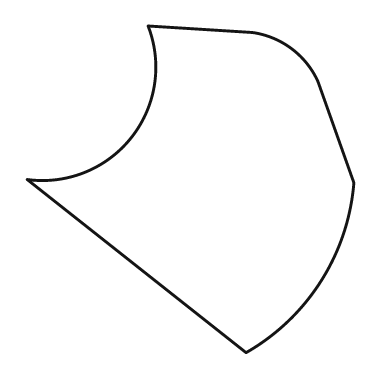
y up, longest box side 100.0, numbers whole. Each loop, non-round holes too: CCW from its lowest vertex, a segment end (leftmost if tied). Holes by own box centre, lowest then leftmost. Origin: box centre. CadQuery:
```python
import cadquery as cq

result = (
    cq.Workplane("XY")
    .moveTo(17.0, -50.0)
    .threePointArc((40.0, -28.0), (50.0, 2.0))
    .lineTo(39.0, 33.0)
    .threePointArc((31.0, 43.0), (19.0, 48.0))
    .lineTo(-13.0, 50.0)
    .threePointArc((-18.0, 16.0), (-50.0, 3.0))
    .close()
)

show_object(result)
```